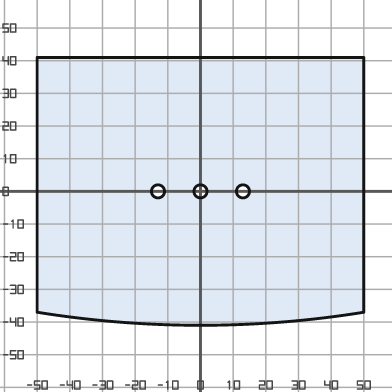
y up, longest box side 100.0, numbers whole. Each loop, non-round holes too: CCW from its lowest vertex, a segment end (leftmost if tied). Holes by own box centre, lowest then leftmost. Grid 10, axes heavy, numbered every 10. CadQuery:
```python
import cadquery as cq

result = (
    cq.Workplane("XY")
    .moveTo(-50.0, -37.0)
    .threePointArc((0.0, -41.0), (50.0, -37.0))
    .lineTo(50.0, 41.0)
    .lineTo(-50.0, 41.0)
    .close()
    .moveTo(-13.0, 0.0)
    .circle(2.0)
    .moveTo(0.0, 0.0)
    .circle(2.0)
    .moveTo(13.0, 0.0)
    .circle(2.0)
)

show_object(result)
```